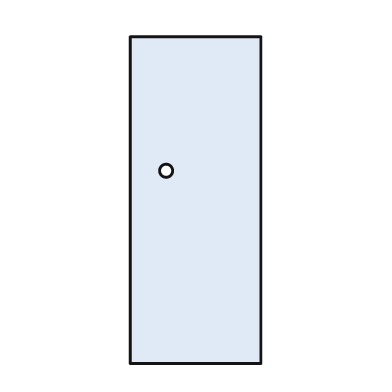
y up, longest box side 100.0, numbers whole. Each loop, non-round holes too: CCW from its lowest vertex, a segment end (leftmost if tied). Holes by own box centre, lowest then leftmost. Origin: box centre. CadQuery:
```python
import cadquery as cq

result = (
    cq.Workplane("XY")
    .moveTo(-20.0, -50.0)
    .lineTo(20.0, -50.0)
    .lineTo(20.0, 50.0)
    .lineTo(-20.0, 50.0)
    .close()
    .moveTo(-9.0, 9.0)
    .circle(2.0)
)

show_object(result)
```